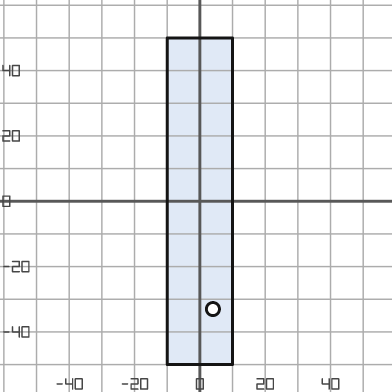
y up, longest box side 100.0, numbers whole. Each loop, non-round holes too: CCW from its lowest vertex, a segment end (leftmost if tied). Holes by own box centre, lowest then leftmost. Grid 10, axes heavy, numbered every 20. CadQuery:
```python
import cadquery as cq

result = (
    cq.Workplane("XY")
    .moveTo(-10.0, -50.0)
    .lineTo(10.0, -50.0)
    .lineTo(10.0, 50.0)
    .lineTo(-10.0, 50.0)
    .close()
    .moveTo(4.0, -33.0)
    .circle(2.0)
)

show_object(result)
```